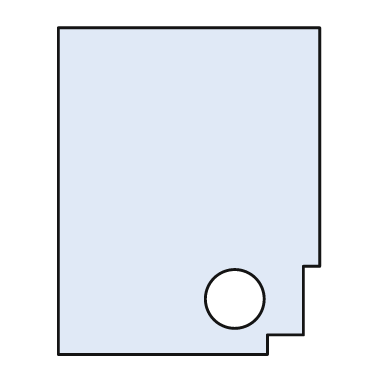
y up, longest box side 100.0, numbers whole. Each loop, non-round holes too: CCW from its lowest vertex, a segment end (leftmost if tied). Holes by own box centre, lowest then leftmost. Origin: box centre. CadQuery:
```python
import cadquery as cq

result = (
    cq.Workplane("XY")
    .moveTo(-40.0, -50.0)
    .lineTo(24.0, -50.0)
    .lineTo(24.0, -44.0)
    .lineTo(35.0, -44.0)
    .lineTo(35.0, -23.0)
    .lineTo(40.0, -23.0)
    .lineTo(40.0, 50.0)
    .lineTo(-40.0, 50.0)
    .close()
    .moveTo(14.0, -33.0)
    .circle(9.0)
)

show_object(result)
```